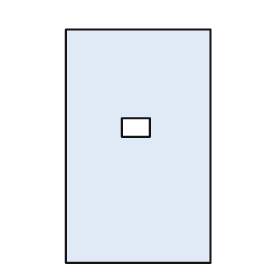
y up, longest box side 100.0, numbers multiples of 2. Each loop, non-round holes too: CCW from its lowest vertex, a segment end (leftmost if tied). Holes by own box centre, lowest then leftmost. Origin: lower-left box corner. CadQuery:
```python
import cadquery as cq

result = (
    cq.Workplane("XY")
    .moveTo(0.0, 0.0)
    .lineTo(62.0, 0.0)
    .lineTo(62.0, 100.0)
    .lineTo(0.0, 100.0)
    .close()
    .moveTo(24.0, 54.0)
    .lineTo(36.0, 54.0)
    .lineTo(36.0, 62.0)
    .lineTo(24.0, 62.0)
    .close()
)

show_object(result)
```